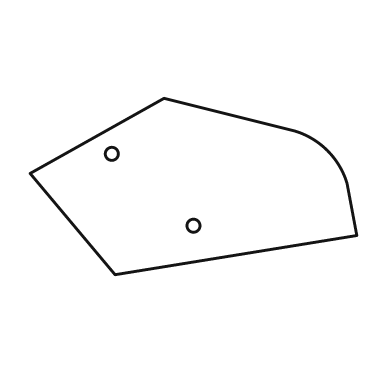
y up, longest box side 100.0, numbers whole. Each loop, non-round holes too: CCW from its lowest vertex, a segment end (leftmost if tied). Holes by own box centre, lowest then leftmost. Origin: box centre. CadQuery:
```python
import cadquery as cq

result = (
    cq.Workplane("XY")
    .moveTo(-24.0, -27.0)
    .lineTo(50.0, -15.0)
    .lineTo(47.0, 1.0)
    .threePointArc((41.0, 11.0), (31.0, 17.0))
    .lineTo(-9.0, 27.0)
    .lineTo(-50.0, 4.0)
    .close()
    .moveTo(0.0, -12.0)
    .circle(2.0)
    .moveTo(-25.0, 10.0)
    .circle(2.0)
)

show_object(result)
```